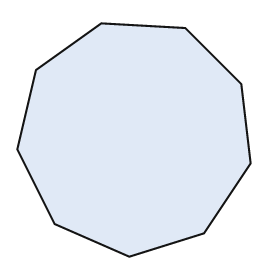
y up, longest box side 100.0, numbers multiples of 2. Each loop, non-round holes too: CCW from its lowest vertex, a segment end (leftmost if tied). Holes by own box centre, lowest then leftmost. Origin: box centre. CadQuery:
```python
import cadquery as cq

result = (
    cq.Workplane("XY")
    .moveTo(-2.0, -50.0)
    .lineTo(30.0, -40.0)
    .lineTo(50.0, -10.0)
    .lineTo(46.0, 24.0)
    .lineTo(22.0, 48.0)
    .lineTo(-14.0, 50.0)
    .lineTo(-42.0, 30.0)
    .lineTo(-50.0, -4.0)
    .lineTo(-34.0, -36.0)
    .close()
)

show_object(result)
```